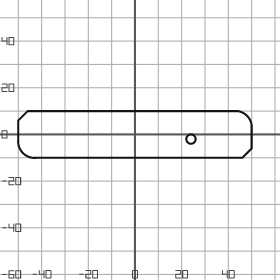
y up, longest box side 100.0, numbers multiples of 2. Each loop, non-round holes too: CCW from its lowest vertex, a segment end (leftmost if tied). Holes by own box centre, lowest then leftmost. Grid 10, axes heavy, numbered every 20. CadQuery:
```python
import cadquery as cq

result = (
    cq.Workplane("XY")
    .moveTo(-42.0, -10.0)
    .lineTo(46.0, -10.0)
    .lineTo(50.0, -6.0)
    .lineTo(50.0, 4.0)
    .threePointArc((48.0, 8.0), (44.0, 10.0))
    .lineTo(-46.0, 10.0)
    .lineTo(-50.0, 6.0)
    .lineTo(-50.0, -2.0)
    .threePointArc((-48.0, -8.0), (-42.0, -10.0))
    .close()
    .moveTo(24.0, -2.0)
    .circle(2.0)
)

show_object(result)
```